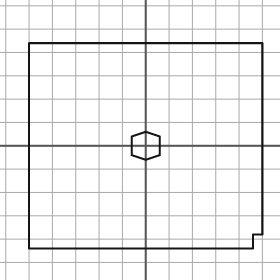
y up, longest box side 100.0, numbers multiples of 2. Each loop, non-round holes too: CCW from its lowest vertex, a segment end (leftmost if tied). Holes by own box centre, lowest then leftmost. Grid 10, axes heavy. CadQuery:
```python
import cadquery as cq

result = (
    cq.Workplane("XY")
    .moveTo(-50.0, -44.0)
    .lineTo(46.0, -44.0)
    .lineTo(46.0, -38.0)
    .lineTo(50.0, -38.0)
    .lineTo(50.0, 44.0)
    .lineTo(-50.0, 44.0)
    .close()
    .moveTo(0.0, -6.0)
    .lineTo(6.0, -4.0)
    .lineTo(6.0, 4.0)
    .lineTo(0.0, 6.0)
    .lineTo(-6.0, 4.0)
    .lineTo(-6.0, -4.0)
    .close()
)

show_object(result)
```